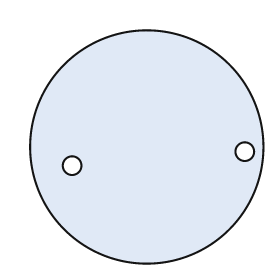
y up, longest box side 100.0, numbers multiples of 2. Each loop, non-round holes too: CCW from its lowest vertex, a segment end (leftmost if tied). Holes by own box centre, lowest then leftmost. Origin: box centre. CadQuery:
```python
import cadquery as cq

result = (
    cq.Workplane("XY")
    .moveTo(0.0, 0.0)
    .circle(50.0)
    .moveTo(-32.0, -8.0)
    .circle(4.0)
    .moveTo(42.0, -2.0)
    .circle(4.0)
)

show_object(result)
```